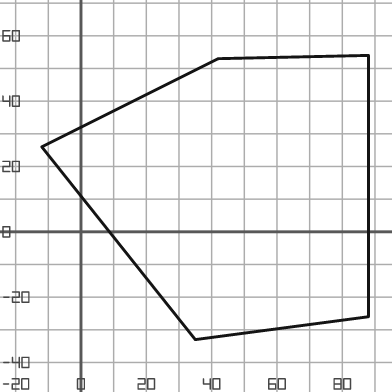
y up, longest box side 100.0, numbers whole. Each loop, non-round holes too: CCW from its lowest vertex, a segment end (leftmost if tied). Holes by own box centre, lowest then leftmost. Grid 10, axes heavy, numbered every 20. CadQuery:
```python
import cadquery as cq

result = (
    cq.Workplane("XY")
    .moveTo(35.0, -33.0)
    .lineTo(88.0, -26.0)
    .lineTo(88.0, 54.0)
    .lineTo(42.0, 53.0)
    .lineTo(-12.0, 26.0)
    .close()
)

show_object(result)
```